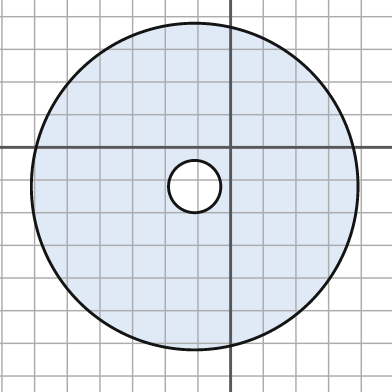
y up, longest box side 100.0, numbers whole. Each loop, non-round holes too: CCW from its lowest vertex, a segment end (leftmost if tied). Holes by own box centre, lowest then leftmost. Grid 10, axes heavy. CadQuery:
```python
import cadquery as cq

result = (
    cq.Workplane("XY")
    .moveTo(-11.0, -12.0)
    .circle(50.0)
    .moveTo(-11.0, -12.0)
    .circle(8.0)
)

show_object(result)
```